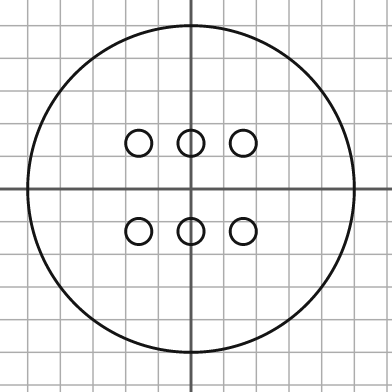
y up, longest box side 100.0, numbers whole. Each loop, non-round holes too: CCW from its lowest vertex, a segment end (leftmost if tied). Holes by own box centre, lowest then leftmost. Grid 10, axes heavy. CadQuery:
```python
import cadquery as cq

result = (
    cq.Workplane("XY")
    .moveTo(0.0, 0.0)
    .circle(50.0)
    .moveTo(-16.0, -13.0)
    .circle(4.0)
    .moveTo(0.0, -13.0)
    .circle(4.0)
    .moveTo(16.0, -13.0)
    .circle(4.0)
    .moveTo(-16.0, 14.0)
    .circle(4.0)
    .moveTo(0.0, 14.0)
    .circle(4.0)
    .moveTo(16.0, 14.0)
    .circle(4.0)
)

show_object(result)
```